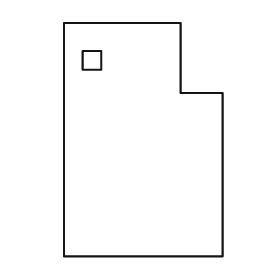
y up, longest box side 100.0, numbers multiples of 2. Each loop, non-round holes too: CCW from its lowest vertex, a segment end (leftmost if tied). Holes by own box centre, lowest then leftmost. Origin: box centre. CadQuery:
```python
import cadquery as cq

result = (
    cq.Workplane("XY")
    .moveTo(-34.0, -50.0)
    .lineTo(34.0, -50.0)
    .lineTo(34.0, 20.0)
    .lineTo(16.0, 20.0)
    .lineTo(16.0, 50.0)
    .lineTo(-34.0, 50.0)
    .close()
    .moveTo(-26.0, 30.0)
    .lineTo(-18.0, 30.0)
    .lineTo(-18.0, 38.0)
    .lineTo(-26.0, 38.0)
    .close()
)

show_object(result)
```